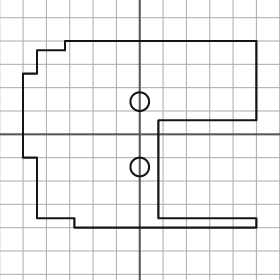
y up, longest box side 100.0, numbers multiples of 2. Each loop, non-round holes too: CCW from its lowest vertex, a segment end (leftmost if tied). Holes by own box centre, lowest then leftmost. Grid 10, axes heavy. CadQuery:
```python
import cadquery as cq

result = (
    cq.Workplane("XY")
    .moveTo(-28.0, -40.0)
    .lineTo(50.0, -40.0)
    .lineTo(50.0, -36.0)
    .lineTo(8.0, -36.0)
    .lineTo(8.0, 6.0)
    .lineTo(50.0, 6.0)
    .lineTo(50.0, 40.0)
    .lineTo(-32.0, 40.0)
    .lineTo(-32.0, 36.0)
    .lineTo(-44.0, 36.0)
    .lineTo(-44.0, 26.0)
    .lineTo(-50.0, 26.0)
    .lineTo(-50.0, -10.0)
    .lineTo(-44.0, -10.0)
    .lineTo(-44.0, -36.0)
    .lineTo(-28.0, -36.0)
    .close()
    .moveTo(0.0, -14.0)
    .circle(4.0)
    .moveTo(0.0, 14.0)
    .circle(4.0)
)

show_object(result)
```